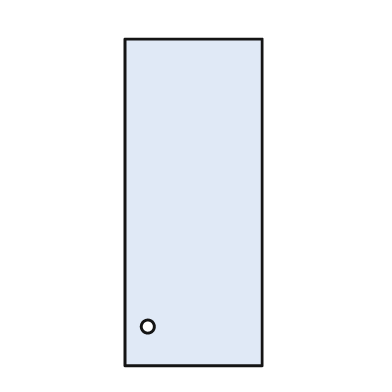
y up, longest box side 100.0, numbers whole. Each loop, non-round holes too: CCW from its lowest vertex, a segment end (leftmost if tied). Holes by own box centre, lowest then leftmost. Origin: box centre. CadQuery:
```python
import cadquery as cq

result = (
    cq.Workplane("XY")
    .moveTo(-21.0, -50.0)
    .lineTo(21.0, -50.0)
    .lineTo(21.0, 50.0)
    .lineTo(-21.0, 50.0)
    .close()
    .moveTo(-14.0, -38.0)
    .circle(2.0)
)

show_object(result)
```